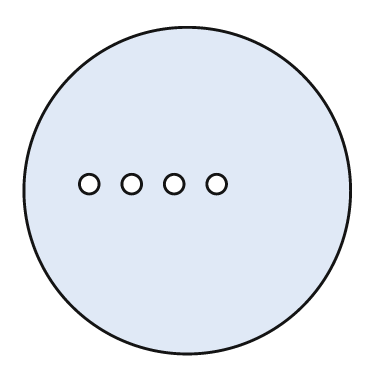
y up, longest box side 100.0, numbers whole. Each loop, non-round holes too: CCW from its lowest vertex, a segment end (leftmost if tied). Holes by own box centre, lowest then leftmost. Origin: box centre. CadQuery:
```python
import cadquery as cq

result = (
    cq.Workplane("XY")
    .moveTo(0.0, 0.0)
    .circle(50.0)
    .moveTo(-30.0, 2.0)
    .circle(3.0)
    .moveTo(-17.0, 2.0)
    .circle(3.0)
    .moveTo(-4.0, 2.0)
    .circle(3.0)
    .moveTo(9.0, 2.0)
    .circle(3.0)
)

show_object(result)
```